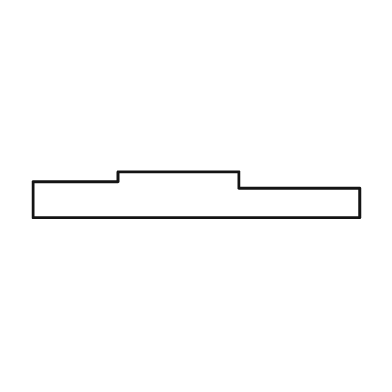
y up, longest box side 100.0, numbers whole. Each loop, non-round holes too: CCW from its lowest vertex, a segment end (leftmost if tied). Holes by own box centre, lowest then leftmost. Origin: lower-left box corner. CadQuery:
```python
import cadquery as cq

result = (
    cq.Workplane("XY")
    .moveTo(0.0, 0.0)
    .lineTo(100.0, 0.0)
    .lineTo(100.0, 9.0)
    .lineTo(63.0, 9.0)
    .lineTo(63.0, 14.0)
    .lineTo(26.0, 14.0)
    .lineTo(26.0, 11.0)
    .lineTo(0.0, 11.0)
    .close()
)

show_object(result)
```